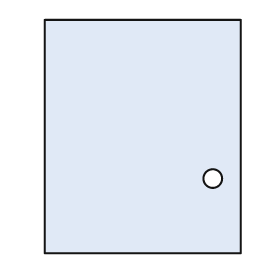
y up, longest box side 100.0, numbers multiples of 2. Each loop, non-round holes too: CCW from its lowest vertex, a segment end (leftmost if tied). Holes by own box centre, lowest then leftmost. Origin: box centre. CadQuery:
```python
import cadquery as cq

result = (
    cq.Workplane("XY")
    .moveTo(-42.0, -50.0)
    .lineTo(42.0, -50.0)
    .lineTo(42.0, 50.0)
    .lineTo(-42.0, 50.0)
    .close()
    .moveTo(30.0, -18.0)
    .circle(4.0)
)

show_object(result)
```